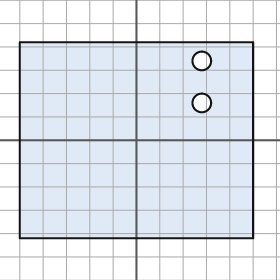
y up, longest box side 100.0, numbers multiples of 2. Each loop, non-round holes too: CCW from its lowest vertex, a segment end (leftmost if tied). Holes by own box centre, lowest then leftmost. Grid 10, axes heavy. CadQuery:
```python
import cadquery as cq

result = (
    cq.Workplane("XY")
    .moveTo(-50.0, -42.0)
    .lineTo(50.0, -42.0)
    .lineTo(50.0, 42.0)
    .lineTo(-50.0, 42.0)
    .close()
    .moveTo(28.0, 16.0)
    .circle(4.0)
    .moveTo(28.0, 34.0)
    .circle(4.0)
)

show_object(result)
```